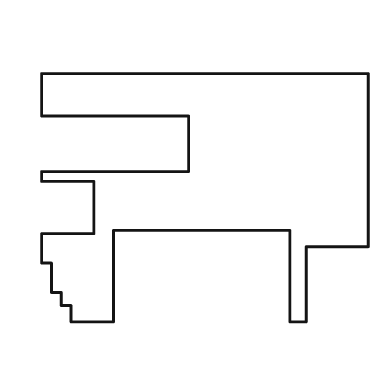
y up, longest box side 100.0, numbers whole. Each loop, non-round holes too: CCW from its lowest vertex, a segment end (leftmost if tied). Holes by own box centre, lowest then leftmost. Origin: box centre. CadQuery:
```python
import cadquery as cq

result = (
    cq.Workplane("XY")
    .moveTo(-41.0, -38.0)
    .lineTo(-28.0, -38.0)
    .lineTo(-28.0, -10.0)
    .lineTo(26.0, -10.0)
    .lineTo(26.0, -38.0)
    .lineTo(31.0, -38.0)
    .lineTo(31.0, -15.0)
    .lineTo(50.0, -15.0)
    .lineTo(50.0, 38.0)
    .lineTo(-50.0, 38.0)
    .lineTo(-50.0, 25.0)
    .lineTo(-5.0, 25.0)
    .lineTo(-5.0, 8.0)
    .lineTo(-50.0, 8.0)
    .lineTo(-50.0, 5.0)
    .lineTo(-34.0, 5.0)
    .lineTo(-34.0, -11.0)
    .lineTo(-50.0, -11.0)
    .lineTo(-50.0, -20.0)
    .lineTo(-47.0, -20.0)
    .lineTo(-47.0, -29.0)
    .lineTo(-44.0, -29.0)
    .lineTo(-44.0, -33.0)
    .lineTo(-41.0, -33.0)
    .close()
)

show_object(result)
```